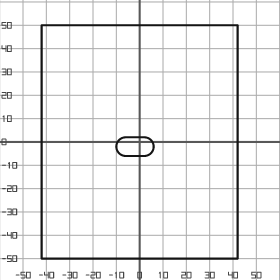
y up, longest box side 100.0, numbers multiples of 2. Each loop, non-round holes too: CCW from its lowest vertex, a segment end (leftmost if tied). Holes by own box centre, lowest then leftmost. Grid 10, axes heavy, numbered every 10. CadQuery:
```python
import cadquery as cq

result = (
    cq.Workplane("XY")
    .moveTo(-42.0, -50.0)
    .lineTo(42.0, -50.0)
    .lineTo(42.0, 50.0)
    .lineTo(-42.0, 50.0)
    .close()
    .moveTo(-6.0, -6.0)
    .lineTo(2.0, -6.0)
    .threePointArc((6.0, -2.0), (2.0, 2.0))
    .lineTo(-6.0, 2.0)
    .threePointArc((-10.0, -2.0), (-6.0, -6.0))
    .close()
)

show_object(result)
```